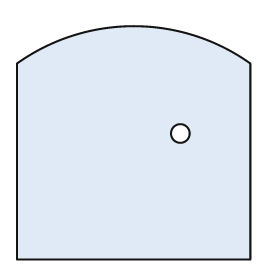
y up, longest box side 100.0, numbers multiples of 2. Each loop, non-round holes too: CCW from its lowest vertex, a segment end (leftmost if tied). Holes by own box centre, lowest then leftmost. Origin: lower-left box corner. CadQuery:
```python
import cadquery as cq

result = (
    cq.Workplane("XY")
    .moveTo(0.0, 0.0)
    .lineTo(100.0, 0.0)
    .lineTo(100.0, 84.0)
    .threePointArc((50.0, 100.0), (0.0, 84.0))
    .close()
    .moveTo(70.0, 54.0)
    .circle(4.0)
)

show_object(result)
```